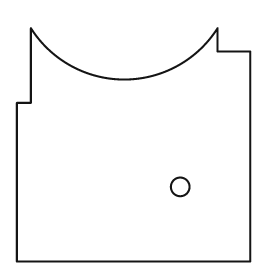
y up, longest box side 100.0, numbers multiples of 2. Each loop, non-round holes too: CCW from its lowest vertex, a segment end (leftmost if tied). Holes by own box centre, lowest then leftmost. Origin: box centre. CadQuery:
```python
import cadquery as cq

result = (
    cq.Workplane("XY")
    .moveTo(-50.0, -50.0)
    .lineTo(50.0, -50.0)
    .lineTo(50.0, 40.0)
    .lineTo(36.0, 40.0)
    .lineTo(36.0, 50.0)
    .threePointArc((-4.0, 28.0), (-44.0, 50.0))
    .lineTo(-44.0, 18.0)
    .lineTo(-50.0, 18.0)
    .close()
    .moveTo(20.0, -18.0)
    .circle(4.0)
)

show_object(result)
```